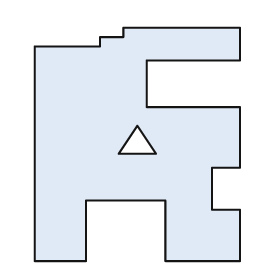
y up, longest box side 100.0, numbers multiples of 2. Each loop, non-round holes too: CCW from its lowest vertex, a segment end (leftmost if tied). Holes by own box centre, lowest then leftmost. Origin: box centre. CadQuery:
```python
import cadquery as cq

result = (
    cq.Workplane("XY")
    .moveTo(-44.0, -50.0)
    .lineTo(-22.0, -50.0)
    .lineTo(-22.0, -24.0)
    .lineTo(12.0, -24.0)
    .lineTo(12.0, -50.0)
    .lineTo(44.0, -50.0)
    .lineTo(44.0, -28.0)
    .lineTo(32.0, -28.0)
    .lineTo(32.0, -10.0)
    .lineTo(44.0, -10.0)
    .lineTo(44.0, 16.0)
    .lineTo(4.0, 16.0)
    .lineTo(4.0, 36.0)
    .lineTo(44.0, 36.0)
    .lineTo(44.0, 50.0)
    .lineTo(-6.0, 50.0)
    .lineTo(-6.0, 46.0)
    .lineTo(-16.0, 46.0)
    .lineTo(-16.0, 42.0)
    .lineTo(-44.0, 42.0)
    .close()
    .moveTo(-8.0, -4.0)
    .lineTo(8.0, -4.0)
    .lineTo(0.0, 8.0)
    .close()
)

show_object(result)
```